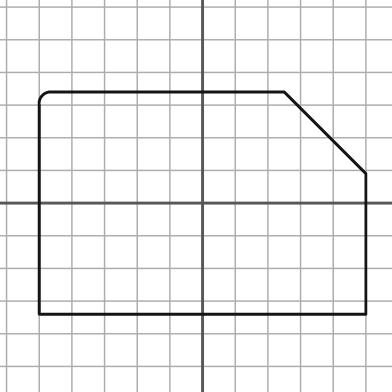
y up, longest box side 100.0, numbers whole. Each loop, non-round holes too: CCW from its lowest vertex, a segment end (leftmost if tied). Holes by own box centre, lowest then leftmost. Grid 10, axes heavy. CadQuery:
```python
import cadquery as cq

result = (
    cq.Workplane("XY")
    .moveTo(-50.0, -34.0)
    .lineTo(50.0, -34.0)
    .lineTo(50.0, 9.0)
    .lineTo(25.0, 34.0)
    .lineTo(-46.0, 34.0)
    .threePointArc((-49.0, 33.0), (-50.0, 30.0))
    .close()
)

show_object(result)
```